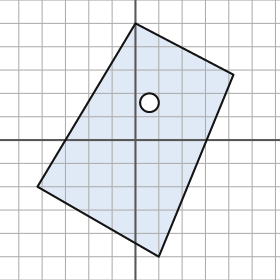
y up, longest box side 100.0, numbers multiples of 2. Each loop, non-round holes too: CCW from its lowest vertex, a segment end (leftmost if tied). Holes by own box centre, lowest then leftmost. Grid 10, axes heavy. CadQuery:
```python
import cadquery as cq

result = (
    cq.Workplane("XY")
    .moveTo(10.0, -50.0)
    .lineTo(42.0, 28.0)
    .lineTo(0.0, 50.0)
    .lineTo(-42.0, -20.0)
    .close()
    .moveTo(6.0, 16.0)
    .circle(4.0)
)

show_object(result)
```